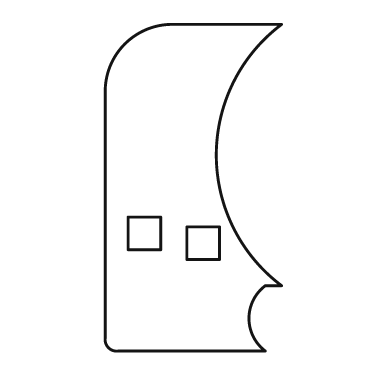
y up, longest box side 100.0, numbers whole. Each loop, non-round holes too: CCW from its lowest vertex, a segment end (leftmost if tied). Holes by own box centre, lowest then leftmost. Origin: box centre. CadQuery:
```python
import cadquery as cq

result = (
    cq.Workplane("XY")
    .moveTo(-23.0, -50.0)
    .lineTo(22.0, -50.0)
    .threePointArc((17.0, -40.0), (22.0, -30.0))
    .lineTo(27.0, -30.0)
    .threePointArc((7.0, 10.0), (27.0, 50.0))
    .lineTo(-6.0, 50.0)
    .threePointArc((-21.0, 44.0), (-27.0, 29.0))
    .lineTo(-27.0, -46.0)
    .threePointArc((-26.0, -49.0), (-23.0, -50.0))
    .close()
    .moveTo(-2.0, -22.0)
    .lineTo(8.0, -22.0)
    .lineTo(8.0, -12.0)
    .lineTo(-2.0, -12.0)
    .close()
    .moveTo(-20.0, -19.0)
    .lineTo(-10.0, -19.0)
    .lineTo(-10.0, -9.0)
    .lineTo(-20.0, -9.0)
    .close()
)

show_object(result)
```